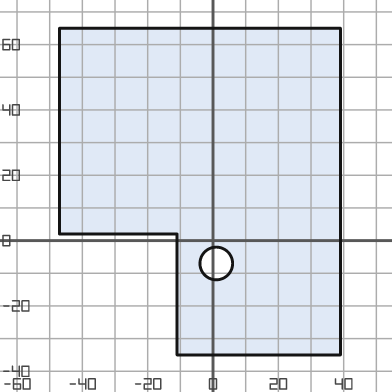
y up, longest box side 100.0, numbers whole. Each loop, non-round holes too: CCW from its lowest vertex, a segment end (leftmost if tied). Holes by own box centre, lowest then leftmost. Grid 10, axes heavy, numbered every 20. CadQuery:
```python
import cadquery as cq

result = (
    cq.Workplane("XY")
    .moveTo(-11.0, -35.0)
    .lineTo(39.0, -35.0)
    .lineTo(39.0, 65.0)
    .lineTo(-47.0, 65.0)
    .lineTo(-47.0, 2.0)
    .lineTo(-11.0, 2.0)
    .close()
    .moveTo(1.0, -7.0)
    .circle(5.0)
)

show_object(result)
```